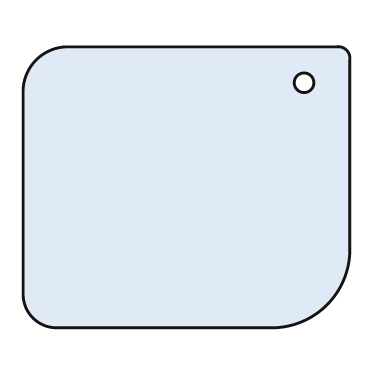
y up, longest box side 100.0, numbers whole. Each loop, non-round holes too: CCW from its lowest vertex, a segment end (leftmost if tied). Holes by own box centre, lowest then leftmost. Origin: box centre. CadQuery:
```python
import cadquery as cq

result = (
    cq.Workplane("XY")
    .moveTo(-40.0, -43.0)
    .lineTo(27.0, -43.0)
    .threePointArc((43.0, -36.0), (50.0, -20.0))
    .lineTo(50.0, 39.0)
    .threePointArc((49.0, 42.0), (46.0, 43.0))
    .lineTo(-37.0, 43.0)
    .threePointArc((-46.0, 39.0), (-50.0, 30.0))
    .lineTo(-50.0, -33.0)
    .threePointArc((-47.0, -40.0), (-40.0, -43.0))
    .close()
    .moveTo(36.0, 32.0)
    .circle(3.0)
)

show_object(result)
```